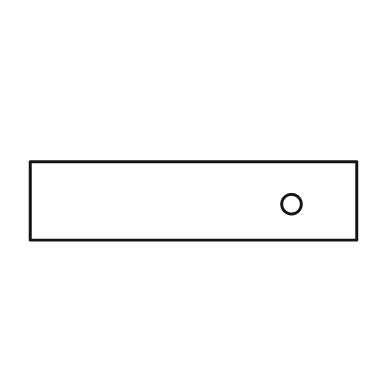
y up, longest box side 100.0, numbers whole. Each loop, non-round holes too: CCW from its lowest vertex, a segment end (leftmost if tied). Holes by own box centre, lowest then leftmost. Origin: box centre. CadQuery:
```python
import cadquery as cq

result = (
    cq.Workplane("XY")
    .moveTo(-50.0, -12.0)
    .lineTo(50.0, -12.0)
    .lineTo(50.0, 12.0)
    .lineTo(-50.0, 12.0)
    .close()
    .moveTo(30.0, -1.0)
    .circle(3.0)
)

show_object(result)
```